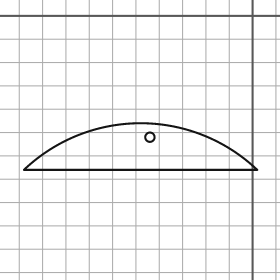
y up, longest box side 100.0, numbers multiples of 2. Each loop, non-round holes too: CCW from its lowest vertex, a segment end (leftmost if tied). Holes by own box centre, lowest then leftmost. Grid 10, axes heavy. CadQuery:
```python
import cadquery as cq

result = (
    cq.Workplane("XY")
    .moveTo(-98.0, -66.0)
    .lineTo(2.0, -66.0)
    .threePointArc((-48.0, -46.0), (-98.0, -66.0))
    .close()
    .moveTo(-44.0, -52.0)
    .circle(2.0)
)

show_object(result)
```